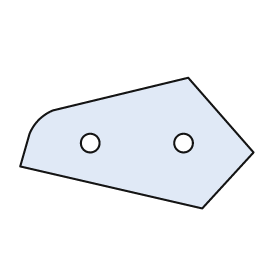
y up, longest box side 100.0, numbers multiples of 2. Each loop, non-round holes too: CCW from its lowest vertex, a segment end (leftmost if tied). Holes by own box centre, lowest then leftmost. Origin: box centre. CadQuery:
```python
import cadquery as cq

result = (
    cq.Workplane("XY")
    .moveTo(28.0, -28.0)
    .lineTo(50.0, -4.0)
    .lineTo(22.0, 28.0)
    .lineTo(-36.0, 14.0)
    .threePointArc((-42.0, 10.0), (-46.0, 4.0))
    .lineTo(-50.0, -10.0)
    .close()
    .moveTo(-20.0, 0.0)
    .circle(4.0)
    .moveTo(20.0, 0.0)
    .circle(4.0)
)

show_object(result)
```